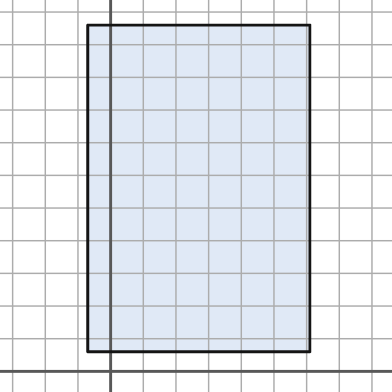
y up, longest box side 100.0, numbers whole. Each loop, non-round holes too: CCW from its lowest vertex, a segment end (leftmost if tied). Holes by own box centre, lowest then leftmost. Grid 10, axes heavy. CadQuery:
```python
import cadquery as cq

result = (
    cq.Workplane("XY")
    .moveTo(-7.0, 6.0)
    .lineTo(61.0, 6.0)
    .lineTo(61.0, 106.0)
    .lineTo(-7.0, 106.0)
    .close()
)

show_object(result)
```